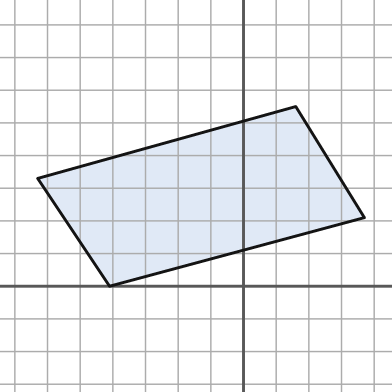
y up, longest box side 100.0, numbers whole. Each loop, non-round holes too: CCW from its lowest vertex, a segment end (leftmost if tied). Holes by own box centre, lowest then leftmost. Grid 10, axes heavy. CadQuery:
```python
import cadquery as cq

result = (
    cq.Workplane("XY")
    .moveTo(-41.0, 0.0)
    .lineTo(37.0, 21.0)
    .lineTo(16.0, 55.0)
    .lineTo(-63.0, 33.0)
    .close()
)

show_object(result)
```